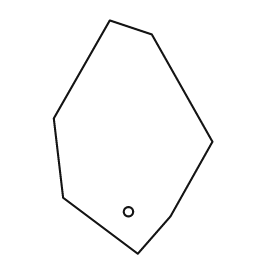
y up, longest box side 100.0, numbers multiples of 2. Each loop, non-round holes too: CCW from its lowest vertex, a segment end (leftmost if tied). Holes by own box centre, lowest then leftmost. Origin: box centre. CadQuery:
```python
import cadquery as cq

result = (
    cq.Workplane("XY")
    .moveTo(2.0, -50.0)
    .lineTo(16.0, -34.0)
    .lineTo(34.0, -2.0)
    .lineTo(8.0, 44.0)
    .lineTo(-10.0, 50.0)
    .lineTo(-34.0, 8.0)
    .lineTo(-30.0, -26.0)
    .close()
    .moveTo(-2.0, -32.0)
    .circle(2.0)
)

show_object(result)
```